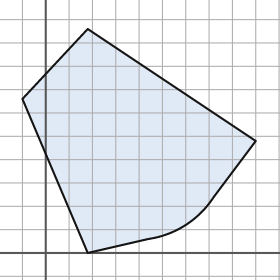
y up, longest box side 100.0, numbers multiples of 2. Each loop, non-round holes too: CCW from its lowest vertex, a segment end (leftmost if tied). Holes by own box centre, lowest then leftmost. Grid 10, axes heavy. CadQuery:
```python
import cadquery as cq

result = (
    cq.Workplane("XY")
    .moveTo(18.0, 0.0)
    .lineTo(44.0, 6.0)
    .threePointArc((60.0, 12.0), (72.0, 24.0))
    .lineTo(90.0, 48.0)
    .lineTo(18.0, 96.0)
    .lineTo(-10.0, 66.0)
    .close()
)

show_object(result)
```